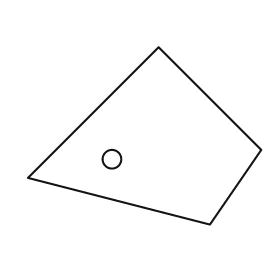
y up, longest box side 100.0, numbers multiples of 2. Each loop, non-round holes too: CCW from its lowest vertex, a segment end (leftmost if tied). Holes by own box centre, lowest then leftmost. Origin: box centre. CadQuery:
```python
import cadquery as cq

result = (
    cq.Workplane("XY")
    .moveTo(28.0, -38.0)
    .lineTo(50.0, -6.0)
    .lineTo(6.0, 38.0)
    .lineTo(-50.0, -18.0)
    .close()
    .moveTo(-14.0, -10.0)
    .circle(4.0)
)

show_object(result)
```